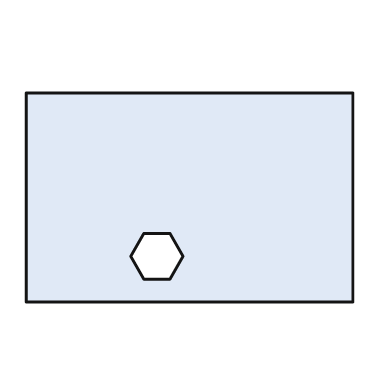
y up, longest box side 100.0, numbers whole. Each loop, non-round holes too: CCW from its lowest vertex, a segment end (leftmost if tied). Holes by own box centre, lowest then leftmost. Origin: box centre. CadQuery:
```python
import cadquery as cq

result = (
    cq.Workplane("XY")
    .moveTo(-50.0, -32.0)
    .lineTo(50.0, -32.0)
    .lineTo(50.0, 32.0)
    .lineTo(-50.0, 32.0)
    .close()
    .moveTo(-14.0, -25.0)
    .lineTo(-6.0, -25.0)
    .lineTo(-2.0, -18.0)
    .lineTo(-6.0, -11.0)
    .lineTo(-14.0, -11.0)
    .lineTo(-18.0, -18.0)
    .close()
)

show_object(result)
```